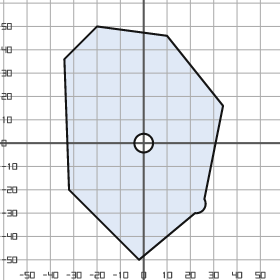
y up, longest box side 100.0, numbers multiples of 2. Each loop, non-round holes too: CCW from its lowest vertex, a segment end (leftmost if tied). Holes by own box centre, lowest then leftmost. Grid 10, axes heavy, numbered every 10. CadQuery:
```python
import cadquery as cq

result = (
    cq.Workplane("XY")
    .moveTo(-2.0, -50.0)
    .lineTo(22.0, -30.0)
    .threePointArc((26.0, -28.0), (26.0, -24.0))
    .lineTo(34.0, 16.0)
    .lineTo(10.0, 46.0)
    .lineTo(-20.0, 50.0)
    .lineTo(-34.0, 36.0)
    .lineTo(-32.0, -20.0)
    .close()
    .moveTo(0.0, 0.0)
    .circle(4.0)
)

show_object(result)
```